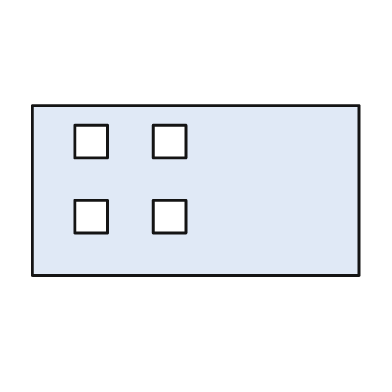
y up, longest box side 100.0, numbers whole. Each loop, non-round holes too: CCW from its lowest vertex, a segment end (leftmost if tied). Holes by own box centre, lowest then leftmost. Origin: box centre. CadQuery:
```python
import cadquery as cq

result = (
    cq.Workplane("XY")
    .moveTo(-50.0, -26.0)
    .lineTo(50.0, -26.0)
    .lineTo(50.0, 26.0)
    .lineTo(-50.0, 26.0)
    .close()
    .moveTo(-37.0, -13.0)
    .lineTo(-27.0, -13.0)
    .lineTo(-27.0, -3.0)
    .lineTo(-37.0, -3.0)
    .close()
    .moveTo(-13.0, -13.0)
    .lineTo(-3.0, -13.0)
    .lineTo(-3.0, -3.0)
    .lineTo(-13.0, -3.0)
    .close()
    .moveTo(-37.0, 10.0)
    .lineTo(-27.0, 10.0)
    .lineTo(-27.0, 20.0)
    .lineTo(-37.0, 20.0)
    .close()
    .moveTo(-13.0, 10.0)
    .lineTo(-3.0, 10.0)
    .lineTo(-3.0, 20.0)
    .lineTo(-13.0, 20.0)
    .close()
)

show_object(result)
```